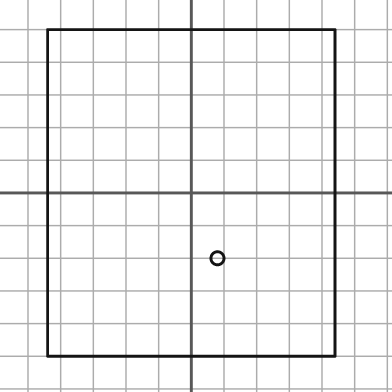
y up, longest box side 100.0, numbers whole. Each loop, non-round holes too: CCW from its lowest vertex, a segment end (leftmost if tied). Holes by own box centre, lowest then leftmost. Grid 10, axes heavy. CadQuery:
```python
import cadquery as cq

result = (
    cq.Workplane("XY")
    .moveTo(-44.0, -50.0)
    .lineTo(44.0, -50.0)
    .lineTo(44.0, 50.0)
    .lineTo(-44.0, 50.0)
    .close()
    .moveTo(8.0, -20.0)
    .circle(2.0)
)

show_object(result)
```